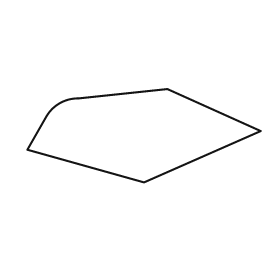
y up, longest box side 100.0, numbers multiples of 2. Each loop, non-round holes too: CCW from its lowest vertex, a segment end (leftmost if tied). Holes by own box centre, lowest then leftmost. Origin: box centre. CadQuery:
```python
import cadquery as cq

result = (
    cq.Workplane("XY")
    .moveTo(0.0, -20.0)
    .lineTo(50.0, 2.0)
    .lineTo(10.0, 20.0)
    .lineTo(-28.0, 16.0)
    .threePointArc((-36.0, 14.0), (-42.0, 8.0))
    .lineTo(-50.0, -6.0)
    .close()
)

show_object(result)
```